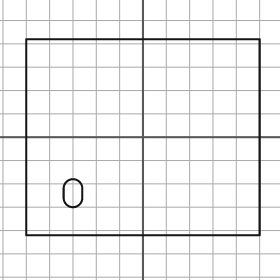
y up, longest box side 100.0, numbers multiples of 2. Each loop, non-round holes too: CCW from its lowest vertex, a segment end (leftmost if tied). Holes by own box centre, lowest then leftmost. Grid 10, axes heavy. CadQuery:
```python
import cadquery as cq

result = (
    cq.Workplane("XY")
    .moveTo(-50.0, -42.0)
    .lineTo(50.0, -42.0)
    .lineTo(50.0, 42.0)
    .lineTo(-50.0, 42.0)
    .close()
    .moveTo(-34.0, -26.0)
    .threePointArc((-30.0, -30.0), (-26.0, -26.0))
    .lineTo(-26.0, -22.0)
    .threePointArc((-30.0, -18.0), (-34.0, -22.0))
    .close()
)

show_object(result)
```